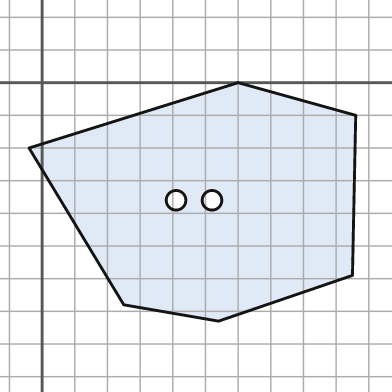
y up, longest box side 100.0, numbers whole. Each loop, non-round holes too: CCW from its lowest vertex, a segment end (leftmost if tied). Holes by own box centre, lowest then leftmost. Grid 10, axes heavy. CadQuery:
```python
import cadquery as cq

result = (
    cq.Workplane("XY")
    .moveTo(54.0, -73.0)
    .lineTo(95.0, -59.0)
    .lineTo(96.0, -10.0)
    .lineTo(60.0, 0.0)
    .lineTo(-4.0, -20.0)
    .lineTo(25.0, -68.0)
    .close()
    .moveTo(41.0, -36.0)
    .circle(3.0)
    .moveTo(52.0, -36.0)
    .circle(3.0)
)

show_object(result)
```